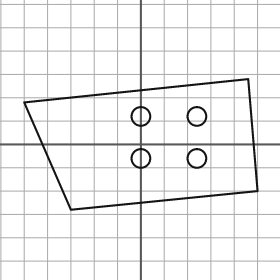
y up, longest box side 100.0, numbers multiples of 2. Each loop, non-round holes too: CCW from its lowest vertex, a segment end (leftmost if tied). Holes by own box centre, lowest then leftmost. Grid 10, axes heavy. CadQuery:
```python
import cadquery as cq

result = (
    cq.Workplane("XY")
    .moveTo(-30.0, -28.0)
    .lineTo(50.0, -20.0)
    .lineTo(46.0, 28.0)
    .lineTo(-50.0, 18.0)
    .close()
    .moveTo(0.0, -6.0)
    .circle(4.0)
    .moveTo(24.0, -6.0)
    .circle(4.0)
    .moveTo(0.0, 12.0)
    .circle(4.0)
    .moveTo(24.0, 12.0)
    .circle(4.0)
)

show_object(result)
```